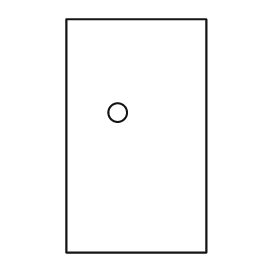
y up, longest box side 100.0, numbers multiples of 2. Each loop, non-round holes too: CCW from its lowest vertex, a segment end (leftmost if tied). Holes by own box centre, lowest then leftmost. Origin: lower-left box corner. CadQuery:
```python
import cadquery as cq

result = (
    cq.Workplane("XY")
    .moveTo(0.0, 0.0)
    .lineTo(60.0, 0.0)
    .lineTo(60.0, 100.0)
    .lineTo(0.0, 100.0)
    .close()
    .moveTo(22.0, 60.0)
    .circle(4.0)
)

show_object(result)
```